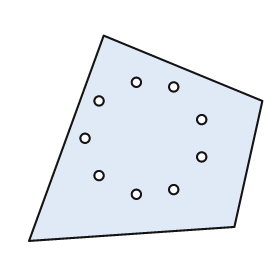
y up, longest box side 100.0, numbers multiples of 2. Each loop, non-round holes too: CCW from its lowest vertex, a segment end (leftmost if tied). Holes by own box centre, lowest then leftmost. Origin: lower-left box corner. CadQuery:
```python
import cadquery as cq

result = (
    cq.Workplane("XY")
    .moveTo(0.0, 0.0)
    .lineTo(88.0, 6.0)
    .lineTo(100.0, 60.0)
    .lineTo(32.0, 88.0)
    .close()
    .moveTo(46.0, 20.0)
    .circle(2.0)
    .moveTo(62.0, 22.0)
    .circle(2.0)
    .moveTo(30.0, 28.0)
    .circle(2.0)
    .moveTo(74.0, 36.0)
    .circle(2.0)
    .moveTo(24.0, 44.0)
    .circle(2.0)
    .moveTo(74.0, 52.0)
    .circle(2.0)
    .moveTo(30.0, 60.0)
    .circle(2.0)
    .moveTo(62.0, 66.0)
    .circle(2.0)
    .moveTo(46.0, 68.0)
    .circle(2.0)
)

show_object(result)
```